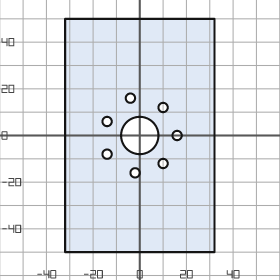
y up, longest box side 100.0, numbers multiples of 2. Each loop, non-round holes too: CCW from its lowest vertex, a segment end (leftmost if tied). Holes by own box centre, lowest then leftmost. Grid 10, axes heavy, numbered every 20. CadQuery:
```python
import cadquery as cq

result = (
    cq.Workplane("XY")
    .moveTo(-32.0, -50.0)
    .lineTo(32.0, -50.0)
    .lineTo(32.0, 50.0)
    .lineTo(-32.0, 50.0)
    .close()
    .moveTo(-2.0, -16.0)
    .circle(2.0)
    .moveTo(10.0, -12.0)
    .circle(2.0)
    .moveTo(-14.0, -8.0)
    .circle(2.0)
    .moveTo(0.0, 0.0)
    .circle(8.0)
    .moveTo(16.0, 0.0)
    .circle(2.0)
    .moveTo(-14.0, 6.0)
    .circle(2.0)
    .moveTo(10.0, 12.0)
    .circle(2.0)
    .moveTo(-4.0, 16.0)
    .circle(2.0)
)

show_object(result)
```